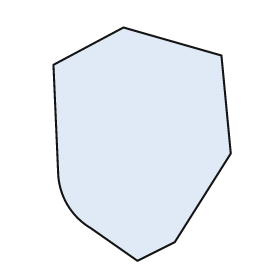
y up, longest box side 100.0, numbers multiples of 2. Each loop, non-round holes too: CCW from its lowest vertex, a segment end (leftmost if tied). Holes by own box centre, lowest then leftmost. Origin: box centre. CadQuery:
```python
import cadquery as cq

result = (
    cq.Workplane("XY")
    .moveTo(-2.0, -50.0)
    .lineTo(14.0, -42.0)
    .lineTo(38.0, -4.0)
    .lineTo(34.0, 38.0)
    .lineTo(-8.0, 50.0)
    .lineTo(-38.0, 34.0)
    .lineTo(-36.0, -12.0)
    .threePointArc((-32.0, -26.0), (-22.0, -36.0))
    .close()
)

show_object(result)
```